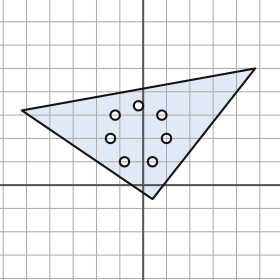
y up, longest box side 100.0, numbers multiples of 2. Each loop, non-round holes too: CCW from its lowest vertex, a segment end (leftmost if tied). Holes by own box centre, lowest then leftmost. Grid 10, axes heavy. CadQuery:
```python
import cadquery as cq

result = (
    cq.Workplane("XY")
    .moveTo(4.0, -6.0)
    .lineTo(48.0, 50.0)
    .lineTo(-52.0, 32.0)
    .close()
    .moveTo(-8.0, 10.0)
    .circle(2.0)
    .moveTo(4.0, 10.0)
    .circle(2.0)
    .moveTo(-14.0, 20.0)
    .circle(2.0)
    .moveTo(10.0, 20.0)
    .circle(2.0)
    .moveTo(-12.0, 30.0)
    .circle(2.0)
    .moveTo(8.0, 30.0)
    .circle(2.0)
    .moveTo(-2.0, 34.0)
    .circle(2.0)
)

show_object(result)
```